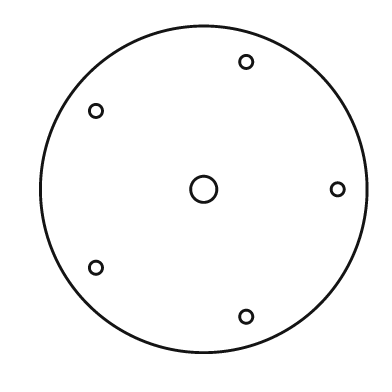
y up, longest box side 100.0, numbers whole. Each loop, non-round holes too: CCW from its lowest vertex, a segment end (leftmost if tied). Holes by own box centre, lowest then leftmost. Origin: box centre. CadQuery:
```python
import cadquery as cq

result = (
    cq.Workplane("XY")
    .moveTo(0.0, 0.0)
    .circle(50.0)
    .moveTo(13.0, -39.0)
    .circle(2.0)
    .moveTo(-33.0, -24.0)
    .circle(2.0)
    .moveTo(0.0, 0.0)
    .circle(4.0)
    .moveTo(41.0, 0.0)
    .circle(2.0)
    .moveTo(-33.0, 24.0)
    .circle(2.0)
    .moveTo(13.0, 39.0)
    .circle(2.0)
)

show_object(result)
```